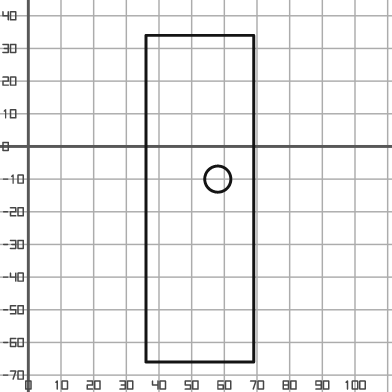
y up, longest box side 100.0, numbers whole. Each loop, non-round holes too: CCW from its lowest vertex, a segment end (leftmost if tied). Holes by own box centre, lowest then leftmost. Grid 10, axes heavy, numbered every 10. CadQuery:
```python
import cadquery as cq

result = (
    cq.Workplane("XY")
    .moveTo(36.0, -66.0)
    .lineTo(69.0, -66.0)
    .lineTo(69.0, 34.0)
    .lineTo(36.0, 34.0)
    .close()
    .moveTo(58.0, -10.0)
    .circle(4.0)
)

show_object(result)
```